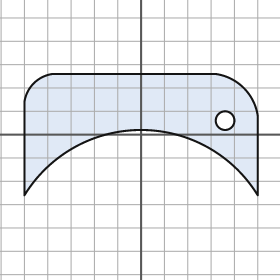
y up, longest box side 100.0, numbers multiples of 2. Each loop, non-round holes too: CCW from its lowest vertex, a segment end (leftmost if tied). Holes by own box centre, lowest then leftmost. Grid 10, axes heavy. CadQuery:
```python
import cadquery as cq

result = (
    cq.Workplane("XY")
    .moveTo(-50.0, -26.0)
    .threePointArc((0.0, 2.0), (50.0, -26.0))
    .lineTo(50.0, 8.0)
    .threePointArc((44.0, 20.0), (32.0, 26.0))
    .lineTo(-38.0, 26.0)
    .threePointArc((-46.0, 22.0), (-50.0, 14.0))
    .close()
    .moveTo(36.0, 6.0)
    .circle(4.0)
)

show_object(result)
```